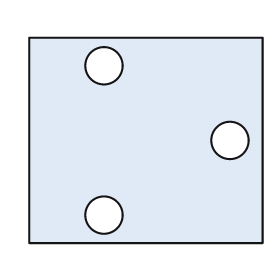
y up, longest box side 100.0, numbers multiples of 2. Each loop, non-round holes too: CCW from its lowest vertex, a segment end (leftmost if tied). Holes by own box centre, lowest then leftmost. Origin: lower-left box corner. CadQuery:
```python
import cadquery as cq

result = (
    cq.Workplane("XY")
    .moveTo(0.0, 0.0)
    .lineTo(100.0, 0.0)
    .lineTo(100.0, 88.0)
    .lineTo(0.0, 88.0)
    .close()
    .moveTo(32.0, 12.0)
    .circle(8.0)
    .moveTo(86.0, 44.0)
    .circle(8.0)
    .moveTo(32.0, 76.0)
    .circle(8.0)
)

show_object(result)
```